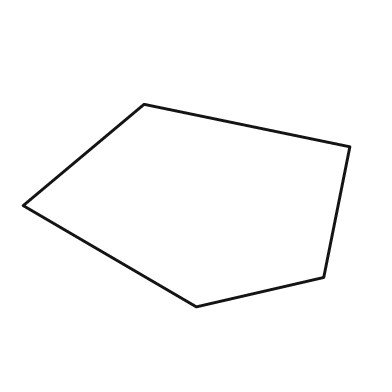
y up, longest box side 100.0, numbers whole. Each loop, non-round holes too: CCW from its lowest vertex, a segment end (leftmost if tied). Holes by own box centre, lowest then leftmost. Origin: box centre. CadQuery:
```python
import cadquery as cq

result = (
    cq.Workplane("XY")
    .moveTo(3.0, -31.0)
    .lineTo(42.0, -22.0)
    .lineTo(50.0, 18.0)
    .lineTo(-13.0, 31.0)
    .lineTo(-50.0, 0.0)
    .close()
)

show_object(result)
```